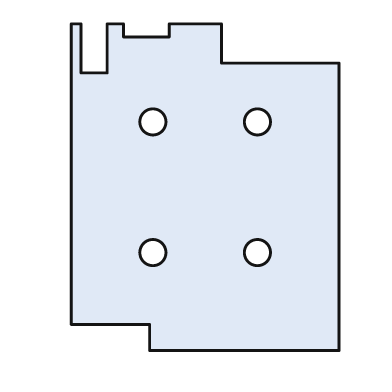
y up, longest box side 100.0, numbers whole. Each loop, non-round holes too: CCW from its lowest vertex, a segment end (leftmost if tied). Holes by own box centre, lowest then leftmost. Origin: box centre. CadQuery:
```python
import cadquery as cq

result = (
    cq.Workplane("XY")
    .moveTo(-17.0, -50.0)
    .lineTo(41.0, -50.0)
    .lineTo(41.0, 38.0)
    .lineTo(5.0, 38.0)
    .lineTo(5.0, 50.0)
    .lineTo(-11.0, 50.0)
    .lineTo(-11.0, 46.0)
    .lineTo(-25.0, 46.0)
    .lineTo(-25.0, 50.0)
    .lineTo(-30.0, 50.0)
    .lineTo(-30.0, 35.0)
    .lineTo(-38.0, 35.0)
    .lineTo(-38.0, 50.0)
    .lineTo(-41.0, 50.0)
    .lineTo(-41.0, -42.0)
    .lineTo(-17.0, -42.0)
    .close()
    .moveTo(-16.0, -20.0)
    .circle(4.0)
    .moveTo(16.0, -20.0)
    .circle(4.0)
    .moveTo(-16.0, 20.0)
    .circle(4.0)
    .moveTo(16.0, 20.0)
    .circle(4.0)
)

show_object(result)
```